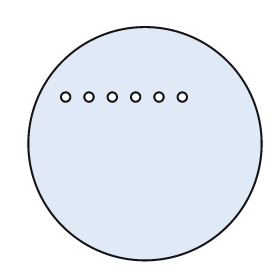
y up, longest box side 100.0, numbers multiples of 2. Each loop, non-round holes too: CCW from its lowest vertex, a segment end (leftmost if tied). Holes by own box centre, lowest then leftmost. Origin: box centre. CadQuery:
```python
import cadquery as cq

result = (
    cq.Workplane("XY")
    .moveTo(0.0, 0.0)
    .circle(50.0)
    .moveTo(-34.0, 20.0)
    .circle(2.0)
    .moveTo(-24.0, 20.0)
    .circle(2.0)
    .moveTo(-14.0, 20.0)
    .circle(2.0)
    .moveTo(-4.0, 20.0)
    .circle(2.0)
    .moveTo(6.0, 20.0)
    .circle(2.0)
    .moveTo(16.0, 20.0)
    .circle(2.0)
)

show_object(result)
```